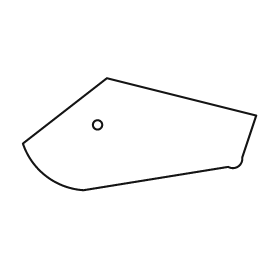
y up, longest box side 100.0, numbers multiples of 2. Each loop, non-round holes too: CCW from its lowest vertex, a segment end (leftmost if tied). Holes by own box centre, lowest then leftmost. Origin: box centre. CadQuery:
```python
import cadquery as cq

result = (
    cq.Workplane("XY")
    .moveTo(-24.0, -24.0)
    .lineTo(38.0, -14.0)
    .threePointArc((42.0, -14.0), (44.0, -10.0))
    .lineTo(50.0, 8.0)
    .lineTo(-14.0, 24.0)
    .lineTo(-50.0, -4.0)
    .threePointArc((-40.0, -18.0), (-24.0, -24.0))
    .close()
    .moveTo(-18.0, 4.0)
    .circle(2.0)
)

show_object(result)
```